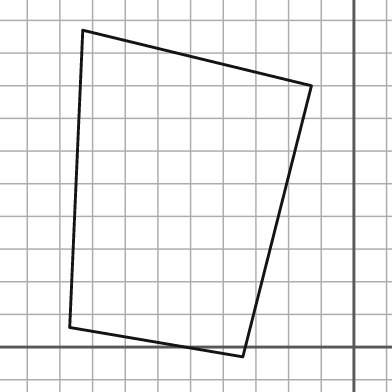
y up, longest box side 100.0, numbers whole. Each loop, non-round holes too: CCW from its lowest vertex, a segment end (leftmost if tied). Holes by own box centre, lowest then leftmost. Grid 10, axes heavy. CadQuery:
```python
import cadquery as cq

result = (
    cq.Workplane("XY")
    .moveTo(-34.0, -3.0)
    .lineTo(-13.0, 80.0)
    .lineTo(-83.0, 97.0)
    .lineTo(-87.0, 6.0)
    .close()
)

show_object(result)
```